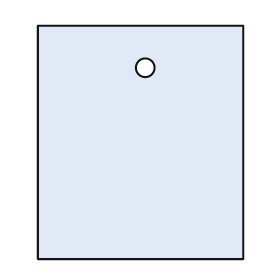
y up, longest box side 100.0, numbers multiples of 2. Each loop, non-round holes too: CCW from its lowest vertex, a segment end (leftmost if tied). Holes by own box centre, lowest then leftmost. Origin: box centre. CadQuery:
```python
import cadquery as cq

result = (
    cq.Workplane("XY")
    .moveTo(-44.0, -50.0)
    .lineTo(44.0, -50.0)
    .lineTo(44.0, 50.0)
    .lineTo(-44.0, 50.0)
    .close()
    .moveTo(2.0, 32.0)
    .circle(4.0)
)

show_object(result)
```